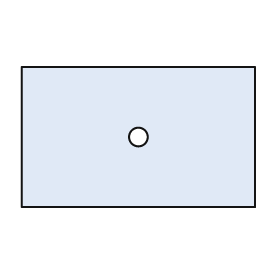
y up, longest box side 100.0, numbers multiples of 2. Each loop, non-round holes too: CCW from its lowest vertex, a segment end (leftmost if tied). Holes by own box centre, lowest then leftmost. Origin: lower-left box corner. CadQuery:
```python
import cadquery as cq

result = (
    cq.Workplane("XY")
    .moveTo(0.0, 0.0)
    .lineTo(100.0, 0.0)
    .lineTo(100.0, 60.0)
    .lineTo(0.0, 60.0)
    .close()
    .moveTo(50.0, 30.0)
    .circle(4.0)
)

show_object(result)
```